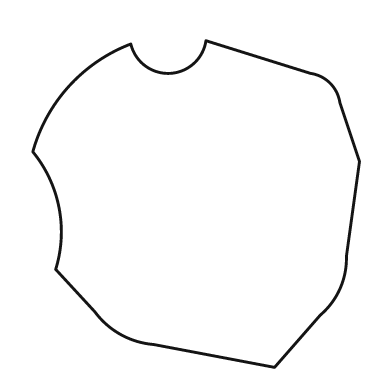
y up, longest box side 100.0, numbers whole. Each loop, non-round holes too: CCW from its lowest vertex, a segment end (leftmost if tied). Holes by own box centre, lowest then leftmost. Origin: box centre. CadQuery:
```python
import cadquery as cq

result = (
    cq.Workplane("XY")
    .moveTo(24.0, -50.0)
    .lineTo(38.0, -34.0)
    .threePointArc((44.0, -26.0), (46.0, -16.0))
    .lineTo(50.0, 13.0)
    .lineTo(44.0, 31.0)
    .threePointArc((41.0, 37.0), (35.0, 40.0))
    .lineTo(3.0, 50.0)
    .threePointArc((-8.0, 40.0), (-20.0, 49.0))
    .threePointArc((-39.0, 36.0), (-50.0, 16.0))
    .threePointArc((-42.0, -1.0), (-43.0, -20.0))
    .lineTo(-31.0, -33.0)
    .threePointArc((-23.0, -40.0), (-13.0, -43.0))
    .close()
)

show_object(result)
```